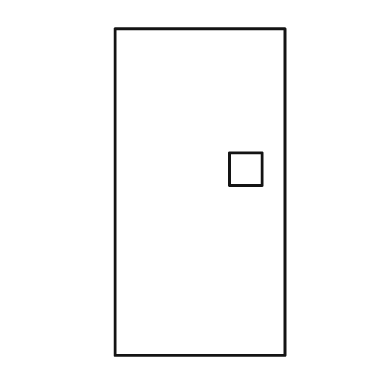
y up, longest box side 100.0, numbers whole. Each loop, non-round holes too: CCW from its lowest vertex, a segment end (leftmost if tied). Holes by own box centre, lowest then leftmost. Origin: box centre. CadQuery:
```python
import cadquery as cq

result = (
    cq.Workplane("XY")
    .moveTo(-26.0, -50.0)
    .lineTo(26.0, -50.0)
    .lineTo(26.0, 50.0)
    .lineTo(-26.0, 50.0)
    .close()
    .moveTo(9.0, 2.0)
    .lineTo(19.0, 2.0)
    .lineTo(19.0, 12.0)
    .lineTo(9.0, 12.0)
    .close()
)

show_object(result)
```